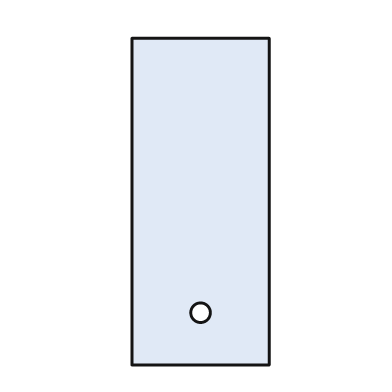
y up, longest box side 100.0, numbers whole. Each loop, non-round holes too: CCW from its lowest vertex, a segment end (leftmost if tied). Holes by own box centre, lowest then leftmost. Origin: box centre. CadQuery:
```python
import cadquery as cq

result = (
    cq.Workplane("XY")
    .moveTo(-21.0, -50.0)
    .lineTo(21.0, -50.0)
    .lineTo(21.0, 50.0)
    .lineTo(-21.0, 50.0)
    .close()
    .moveTo(0.0, -34.0)
    .circle(3.0)
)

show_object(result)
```